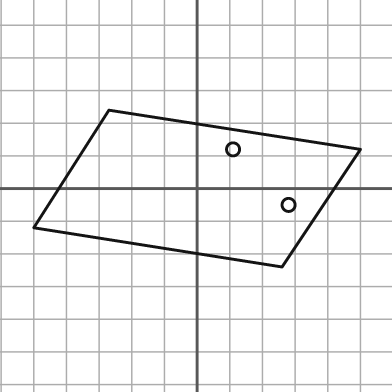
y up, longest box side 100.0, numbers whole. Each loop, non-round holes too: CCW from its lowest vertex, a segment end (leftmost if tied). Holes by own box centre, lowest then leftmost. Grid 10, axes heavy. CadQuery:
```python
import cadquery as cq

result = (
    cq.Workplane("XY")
    .moveTo(26.0, -24.0)
    .lineTo(50.0, 12.0)
    .lineTo(-27.0, 24.0)
    .lineTo(-50.0, -12.0)
    .close()
    .moveTo(28.0, -5.0)
    .circle(2.0)
    .moveTo(11.0, 12.0)
    .circle(2.0)
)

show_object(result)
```